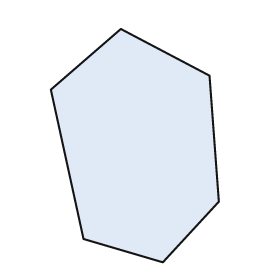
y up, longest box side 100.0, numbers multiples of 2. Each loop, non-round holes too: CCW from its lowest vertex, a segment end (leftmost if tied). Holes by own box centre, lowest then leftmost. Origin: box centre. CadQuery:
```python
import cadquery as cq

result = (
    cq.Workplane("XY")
    .moveTo(12.0, -50.0)
    .lineTo(36.0, -24.0)
    .lineTo(32.0, 30.0)
    .lineTo(-6.0, 50.0)
    .lineTo(-36.0, 24.0)
    .lineTo(-22.0, -40.0)
    .close()
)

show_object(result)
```